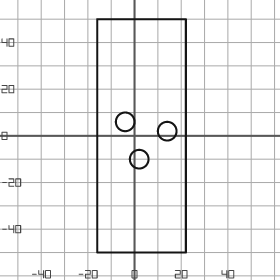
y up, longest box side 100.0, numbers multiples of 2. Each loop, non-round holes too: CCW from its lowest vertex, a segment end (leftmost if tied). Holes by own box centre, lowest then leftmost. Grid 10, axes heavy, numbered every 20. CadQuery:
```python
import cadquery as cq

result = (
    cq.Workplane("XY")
    .moveTo(-16.0, -50.0)
    .lineTo(22.0, -50.0)
    .lineTo(22.0, 50.0)
    .lineTo(-16.0, 50.0)
    .close()
    .moveTo(2.0, -10.0)
    .circle(4.0)
    .moveTo(14.0, 2.0)
    .circle(4.0)
    .moveTo(-4.0, 6.0)
    .circle(4.0)
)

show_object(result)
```